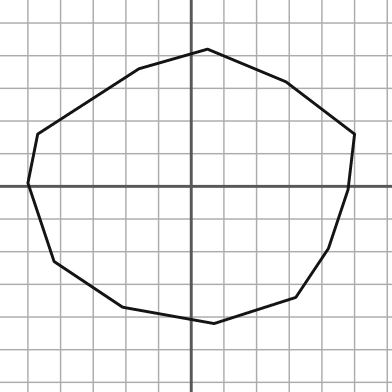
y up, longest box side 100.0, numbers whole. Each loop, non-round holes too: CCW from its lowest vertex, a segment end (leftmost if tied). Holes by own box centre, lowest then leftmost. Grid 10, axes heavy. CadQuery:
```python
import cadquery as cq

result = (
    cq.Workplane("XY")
    .moveTo(7.0, -42.0)
    .lineTo(32.0, -34.0)
    .lineTo(42.0, -19.0)
    .lineTo(48.0, -1.0)
    .lineTo(50.0, 16.0)
    .lineTo(29.0, 32.0)
    .lineTo(5.0, 42.0)
    .lineTo(-16.0, 36.0)
    .lineTo(-47.0, 16.0)
    .lineTo(-50.0, 1.0)
    .lineTo(-42.0, -23.0)
    .lineTo(-21.0, -37.0)
    .close()
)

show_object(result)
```